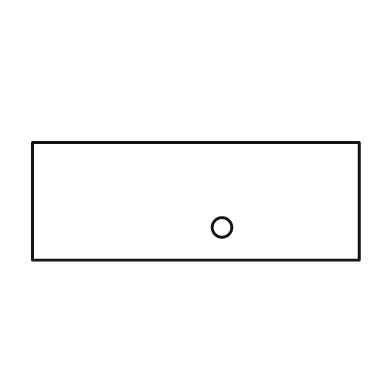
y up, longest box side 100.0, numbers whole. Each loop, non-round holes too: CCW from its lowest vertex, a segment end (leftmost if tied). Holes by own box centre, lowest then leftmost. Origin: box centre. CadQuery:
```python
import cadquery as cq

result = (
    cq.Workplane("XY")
    .moveTo(-50.0, -18.0)
    .lineTo(50.0, -18.0)
    .lineTo(50.0, 18.0)
    .lineTo(-50.0, 18.0)
    .close()
    .moveTo(8.0, -8.0)
    .circle(3.0)
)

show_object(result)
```